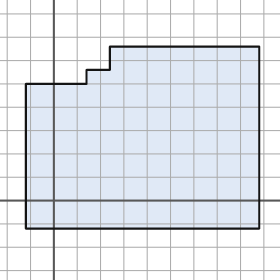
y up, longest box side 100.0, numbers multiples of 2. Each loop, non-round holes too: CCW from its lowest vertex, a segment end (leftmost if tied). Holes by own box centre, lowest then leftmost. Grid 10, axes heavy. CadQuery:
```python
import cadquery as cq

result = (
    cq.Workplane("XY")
    .moveTo(-12.0, -12.0)
    .lineTo(88.0, -12.0)
    .lineTo(88.0, 66.0)
    .lineTo(24.0, 66.0)
    .lineTo(24.0, 56.0)
    .lineTo(14.0, 56.0)
    .lineTo(14.0, 50.0)
    .lineTo(-12.0, 50.0)
    .close()
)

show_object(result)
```